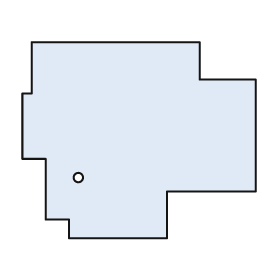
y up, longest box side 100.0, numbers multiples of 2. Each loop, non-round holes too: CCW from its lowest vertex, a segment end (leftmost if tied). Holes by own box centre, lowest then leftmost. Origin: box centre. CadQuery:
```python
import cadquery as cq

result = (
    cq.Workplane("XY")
    .moveTo(-30.0, -42.0)
    .lineTo(12.0, -42.0)
    .lineTo(12.0, -22.0)
    .lineTo(50.0, -22.0)
    .lineTo(50.0, 26.0)
    .lineTo(26.0, 26.0)
    .lineTo(26.0, 42.0)
    .lineTo(-46.0, 42.0)
    .lineTo(-46.0, 20.0)
    .lineTo(-50.0, 20.0)
    .lineTo(-50.0, -8.0)
    .lineTo(-40.0, -8.0)
    .lineTo(-40.0, -34.0)
    .lineTo(-30.0, -34.0)
    .close()
    .moveTo(-26.0, -16.0)
    .circle(2.0)
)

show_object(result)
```